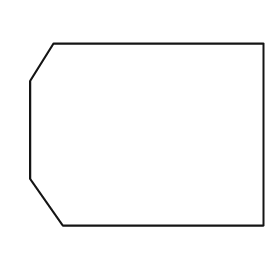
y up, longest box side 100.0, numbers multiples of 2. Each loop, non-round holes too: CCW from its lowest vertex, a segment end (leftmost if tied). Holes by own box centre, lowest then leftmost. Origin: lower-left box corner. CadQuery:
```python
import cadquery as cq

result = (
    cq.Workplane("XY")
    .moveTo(14.0, 0.0)
    .lineTo(100.0, 0.0)
    .lineTo(100.0, 78.0)
    .lineTo(10.0, 78.0)
    .lineTo(0.0, 62.0)
    .lineTo(0.0, 20.0)
    .close()
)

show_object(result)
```